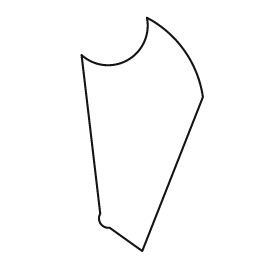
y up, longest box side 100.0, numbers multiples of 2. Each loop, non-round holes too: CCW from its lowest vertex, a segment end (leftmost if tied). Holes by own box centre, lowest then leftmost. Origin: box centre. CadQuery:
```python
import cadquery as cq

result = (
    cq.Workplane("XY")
    .moveTo(0.0, -50.0)
    .lineTo(26.0, 16.0)
    .threePointArc((18.0, 36.0), (2.0, 50.0))
    .threePointArc((-6.0, 32.0), (-26.0, 34.0))
    .lineTo(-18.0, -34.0)
    .threePointArc((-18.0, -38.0), (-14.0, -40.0))
    .close()
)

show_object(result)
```